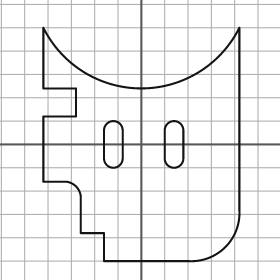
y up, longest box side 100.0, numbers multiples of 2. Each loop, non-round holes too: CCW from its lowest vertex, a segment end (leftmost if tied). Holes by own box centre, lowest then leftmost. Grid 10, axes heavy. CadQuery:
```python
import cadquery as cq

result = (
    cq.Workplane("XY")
    .moveTo(-16.0, -50.0)
    .lineTo(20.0, -50.0)
    .threePointArc((36.0, -44.0), (42.0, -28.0))
    .lineTo(42.0, 50.0)
    .threePointArc((0.0, 24.0), (-42.0, 50.0))
    .lineTo(-42.0, 24.0)
    .lineTo(-28.0, 24.0)
    .lineTo(-28.0, 12.0)
    .lineTo(-42.0, 12.0)
    .lineTo(-42.0, -16.0)
    .lineTo(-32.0, -16.0)
    .threePointArc((-28.0, -18.0), (-26.0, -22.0))
    .lineTo(-26.0, -38.0)
    .lineTo(-16.0, -38.0)
    .close()
    .moveTo(-16.0, -6.0)
    .threePointArc((-12.0, -10.0), (-8.0, -6.0))
    .lineTo(-8.0, 6.0)
    .threePointArc((-12.0, 10.0), (-16.0, 6.0))
    .close()
    .moveTo(10.0, -6.0)
    .threePointArc((14.0, -10.0), (18.0, -6.0))
    .lineTo(18.0, 6.0)
    .threePointArc((14.0, 10.0), (10.0, 6.0))
    .close()
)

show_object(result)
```